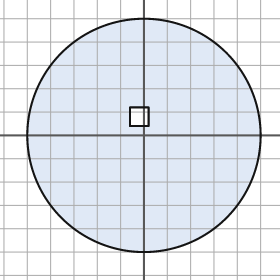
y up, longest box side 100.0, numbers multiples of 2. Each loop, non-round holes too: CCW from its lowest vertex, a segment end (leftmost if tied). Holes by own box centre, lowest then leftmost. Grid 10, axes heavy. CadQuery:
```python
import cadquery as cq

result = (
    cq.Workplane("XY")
    .moveTo(0.0, 0.0)
    .circle(50.0)
    .moveTo(-6.0, 4.0)
    .lineTo(2.0, 4.0)
    .lineTo(2.0, 12.0)
    .lineTo(-6.0, 12.0)
    .close()
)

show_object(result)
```